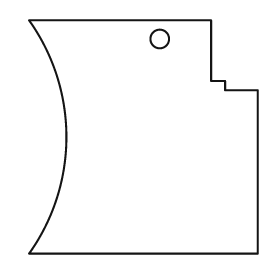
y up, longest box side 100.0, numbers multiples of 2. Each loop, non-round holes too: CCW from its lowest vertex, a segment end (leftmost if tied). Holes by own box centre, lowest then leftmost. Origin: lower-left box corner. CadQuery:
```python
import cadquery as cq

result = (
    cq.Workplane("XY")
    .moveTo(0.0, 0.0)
    .lineTo(98.0, 0.0)
    .lineTo(98.0, 70.0)
    .lineTo(84.0, 70.0)
    .lineTo(84.0, 74.0)
    .lineTo(78.0, 74.0)
    .lineTo(78.0, 100.0)
    .lineTo(0.0, 100.0)
    .threePointArc((16.0, 50.0), (0.0, 0.0))
    .close()
    .moveTo(56.0, 92.0)
    .circle(4.0)
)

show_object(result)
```